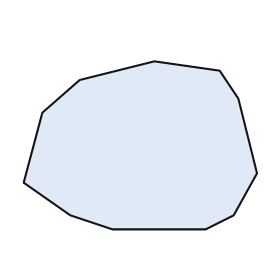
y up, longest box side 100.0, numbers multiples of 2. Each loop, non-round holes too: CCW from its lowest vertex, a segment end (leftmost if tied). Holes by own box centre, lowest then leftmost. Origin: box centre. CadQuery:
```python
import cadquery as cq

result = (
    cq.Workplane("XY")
    .moveTo(-12.0, -36.0)
    .lineTo(28.0, -36.0)
    .lineTo(40.0, -30.0)
    .lineTo(50.0, -12.0)
    .lineTo(42.0, 20.0)
    .lineTo(34.0, 32.0)
    .lineTo(6.0, 36.0)
    .lineTo(-26.0, 28.0)
    .lineTo(-42.0, 14.0)
    .lineTo(-50.0, -16.0)
    .lineTo(-30.0, -30.0)
    .close()
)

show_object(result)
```